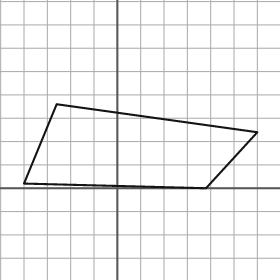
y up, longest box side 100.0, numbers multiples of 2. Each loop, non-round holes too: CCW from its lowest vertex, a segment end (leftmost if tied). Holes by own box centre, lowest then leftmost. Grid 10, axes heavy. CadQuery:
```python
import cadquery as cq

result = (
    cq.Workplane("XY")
    .moveTo(38.0, 0.0)
    .lineTo(60.0, 24.0)
    .lineTo(-26.0, 36.0)
    .lineTo(-40.0, 2.0)
    .close()
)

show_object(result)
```